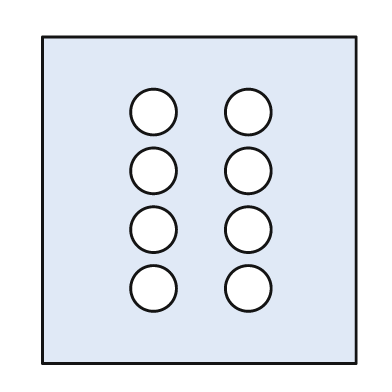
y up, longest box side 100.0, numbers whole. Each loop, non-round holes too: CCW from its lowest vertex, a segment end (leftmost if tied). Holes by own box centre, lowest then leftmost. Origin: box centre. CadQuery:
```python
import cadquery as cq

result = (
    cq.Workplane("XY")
    .moveTo(-48.0, -50.0)
    .lineTo(48.0, -50.0)
    .lineTo(48.0, 50.0)
    .lineTo(-48.0, 50.0)
    .close()
    .moveTo(-14.0, -27.0)
    .circle(7.0)
    .moveTo(15.0, -27.0)
    .circle(7.0)
    .moveTo(-14.0, -9.0)
    .circle(7.0)
    .moveTo(15.0, -9.0)
    .circle(7.0)
    .moveTo(-14.0, 9.0)
    .circle(7.0)
    .moveTo(15.0, 9.0)
    .circle(7.0)
    .moveTo(-14.0, 27.0)
    .circle(7.0)
    .moveTo(15.0, 27.0)
    .circle(7.0)
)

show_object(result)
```